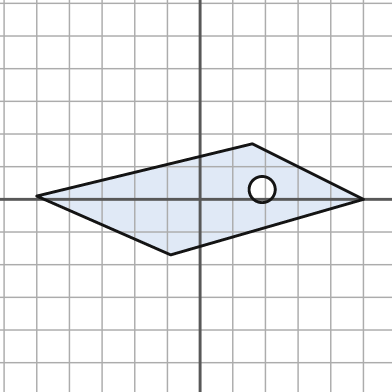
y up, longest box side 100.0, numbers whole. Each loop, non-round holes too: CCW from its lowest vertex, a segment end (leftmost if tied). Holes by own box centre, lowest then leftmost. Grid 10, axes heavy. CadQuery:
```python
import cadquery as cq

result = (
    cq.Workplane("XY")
    .moveTo(-9.0, -17.0)
    .lineTo(50.0, 0.0)
    .lineTo(16.0, 17.0)
    .lineTo(-50.0, 1.0)
    .close()
    .moveTo(19.0, 3.0)
    .circle(4.0)
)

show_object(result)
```